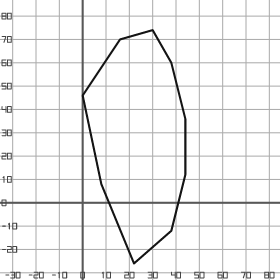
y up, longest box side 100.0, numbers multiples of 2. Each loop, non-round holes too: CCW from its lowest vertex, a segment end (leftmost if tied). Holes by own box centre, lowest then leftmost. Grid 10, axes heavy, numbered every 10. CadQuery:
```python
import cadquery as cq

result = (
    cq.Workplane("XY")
    .moveTo(22.0, -26.0)
    .lineTo(38.0, -12.0)
    .lineTo(44.0, 12.0)
    .lineTo(44.0, 36.0)
    .lineTo(38.0, 60.0)
    .lineTo(30.0, 74.0)
    .lineTo(16.0, 70.0)
    .lineTo(0.0, 46.0)
    .lineTo(8.0, 8.0)
    .close()
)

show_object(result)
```